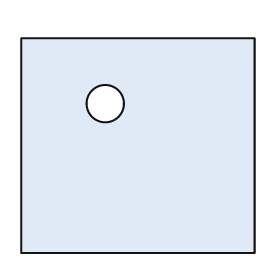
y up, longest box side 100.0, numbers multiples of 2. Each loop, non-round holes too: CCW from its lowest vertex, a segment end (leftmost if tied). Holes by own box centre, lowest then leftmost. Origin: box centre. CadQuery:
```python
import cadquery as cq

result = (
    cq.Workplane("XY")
    .moveTo(-50.0, -46.0)
    .lineTo(50.0, -46.0)
    .lineTo(50.0, 46.0)
    .lineTo(-50.0, 46.0)
    .close()
    .moveTo(-14.0, 18.0)
    .circle(8.0)
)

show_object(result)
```